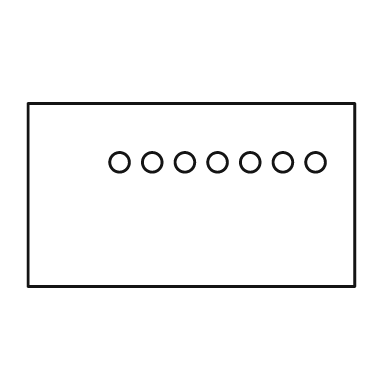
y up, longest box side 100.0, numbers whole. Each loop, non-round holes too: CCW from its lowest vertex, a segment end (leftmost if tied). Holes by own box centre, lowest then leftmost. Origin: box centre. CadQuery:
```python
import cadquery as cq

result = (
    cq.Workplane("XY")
    .moveTo(-50.0, -28.0)
    .lineTo(50.0, -28.0)
    .lineTo(50.0, 28.0)
    .lineTo(-50.0, 28.0)
    .close()
    .moveTo(-22.0, 10.0)
    .circle(3.0)
    .moveTo(-12.0, 10.0)
    .circle(3.0)
    .moveTo(-2.0, 10.0)
    .circle(3.0)
    .moveTo(8.0, 10.0)
    .circle(3.0)
    .moveTo(18.0, 10.0)
    .circle(3.0)
    .moveTo(28.0, 10.0)
    .circle(3.0)
    .moveTo(38.0, 10.0)
    .circle(3.0)
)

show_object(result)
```